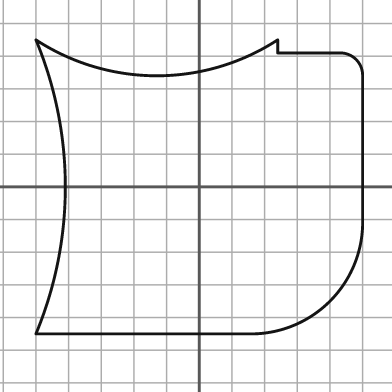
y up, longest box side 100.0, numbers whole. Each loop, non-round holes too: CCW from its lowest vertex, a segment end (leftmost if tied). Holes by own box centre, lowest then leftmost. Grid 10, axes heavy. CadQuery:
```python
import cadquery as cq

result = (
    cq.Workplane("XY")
    .moveTo(-50.0, -45.0)
    .lineTo(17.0, -45.0)
    .threePointArc((40.0, -35.0), (50.0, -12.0))
    .lineTo(50.0, 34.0)
    .threePointArc((48.0, 39.0), (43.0, 41.0))
    .lineTo(24.0, 41.0)
    .lineTo(24.0, 45.0)
    .threePointArc((-13.0, 34.0), (-50.0, 45.0))
    .threePointArc((-41.0, 0.0), (-50.0, -45.0))
    .close()
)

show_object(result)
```